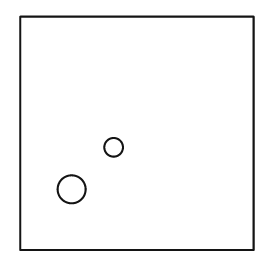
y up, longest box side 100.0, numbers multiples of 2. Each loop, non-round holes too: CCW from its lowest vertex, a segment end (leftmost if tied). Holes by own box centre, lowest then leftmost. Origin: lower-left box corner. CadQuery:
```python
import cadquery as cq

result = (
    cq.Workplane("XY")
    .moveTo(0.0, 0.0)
    .lineTo(100.0, 0.0)
    .lineTo(100.0, 100.0)
    .lineTo(0.0, 100.0)
    .close()
    .moveTo(22.0, 26.0)
    .circle(6.0)
    .moveTo(40.0, 44.0)
    .circle(4.0)
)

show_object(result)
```